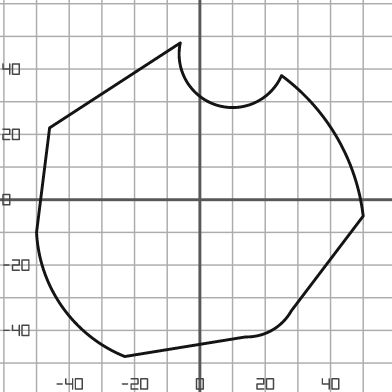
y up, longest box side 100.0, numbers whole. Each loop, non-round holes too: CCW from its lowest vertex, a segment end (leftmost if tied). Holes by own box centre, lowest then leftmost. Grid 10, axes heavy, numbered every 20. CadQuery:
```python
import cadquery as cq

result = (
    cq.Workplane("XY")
    .moveTo(-23.0, -48.0)
    .lineTo(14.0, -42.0)
    .threePointArc((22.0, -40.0), (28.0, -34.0))
    .lineTo(50.0, -5.0)
    .threePointArc((42.0, 19.0), (25.0, 38.0))
    .threePointArc((5.0, 29.0), (-6.0, 48.0))
    .lineTo(-46.0, 22.0)
    .lineTo(-50.0, -10.0)
    .threePointArc((-42.0, -33.0), (-23.0, -48.0))
    .close()
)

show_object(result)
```